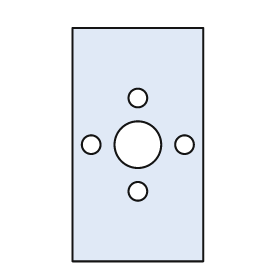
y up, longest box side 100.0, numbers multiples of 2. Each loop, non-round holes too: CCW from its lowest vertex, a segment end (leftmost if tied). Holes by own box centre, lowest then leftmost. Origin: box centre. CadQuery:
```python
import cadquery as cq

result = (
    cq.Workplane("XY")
    .moveTo(-28.0, -50.0)
    .lineTo(28.0, -50.0)
    .lineTo(28.0, 50.0)
    .lineTo(-28.0, 50.0)
    .close()
    .moveTo(0.0, -20.0)
    .circle(4.0)
    .moveTo(-20.0, 0.0)
    .circle(4.0)
    .moveTo(0.0, 0.0)
    .circle(10.0)
    .moveTo(20.0, 0.0)
    .circle(4.0)
    .moveTo(0.0, 20.0)
    .circle(4.0)
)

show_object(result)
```